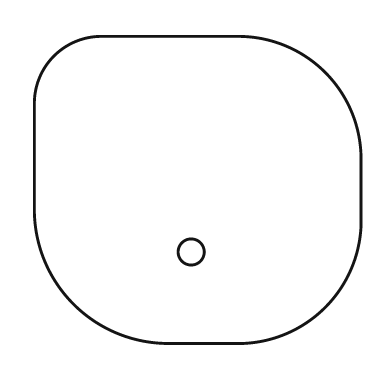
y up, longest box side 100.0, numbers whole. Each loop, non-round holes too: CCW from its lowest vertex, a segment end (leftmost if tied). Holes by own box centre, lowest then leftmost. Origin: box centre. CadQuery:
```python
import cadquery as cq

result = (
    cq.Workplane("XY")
    .moveTo(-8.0, -47.0)
    .lineTo(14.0, -47.0)
    .threePointArc((39.0, -36.0), (50.0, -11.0))
    .lineTo(50.0, 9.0)
    .threePointArc((39.0, 36.0), (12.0, 47.0))
    .lineTo(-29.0, 47.0)
    .threePointArc((-44.0, 41.0), (-50.0, 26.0))
    .lineTo(-50.0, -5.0)
    .threePointArc((-38.0, -35.0), (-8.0, -47.0))
    .close()
    .moveTo(-2.0, -19.0)
    .circle(4.0)
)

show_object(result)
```